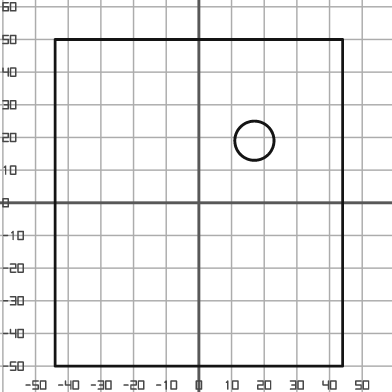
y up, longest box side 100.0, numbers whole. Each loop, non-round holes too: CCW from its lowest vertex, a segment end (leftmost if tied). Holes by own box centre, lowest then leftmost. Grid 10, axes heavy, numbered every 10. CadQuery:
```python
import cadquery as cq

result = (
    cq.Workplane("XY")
    .moveTo(-44.0, -50.0)
    .lineTo(44.0, -50.0)
    .lineTo(44.0, 50.0)
    .lineTo(-44.0, 50.0)
    .close()
    .moveTo(17.0, 19.0)
    .circle(6.0)
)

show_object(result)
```